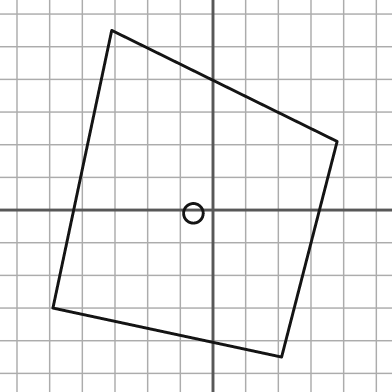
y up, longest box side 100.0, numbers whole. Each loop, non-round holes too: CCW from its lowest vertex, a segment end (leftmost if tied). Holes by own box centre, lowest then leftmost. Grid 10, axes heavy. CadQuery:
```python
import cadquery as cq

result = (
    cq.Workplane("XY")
    .moveTo(21.0, -45.0)
    .lineTo(38.0, 21.0)
    .lineTo(-31.0, 55.0)
    .lineTo(-49.0, -30.0)
    .close()
    .moveTo(-6.0, -1.0)
    .circle(3.0)
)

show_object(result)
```